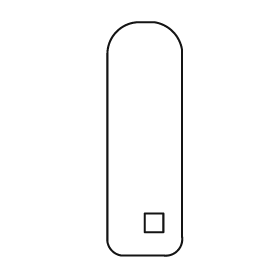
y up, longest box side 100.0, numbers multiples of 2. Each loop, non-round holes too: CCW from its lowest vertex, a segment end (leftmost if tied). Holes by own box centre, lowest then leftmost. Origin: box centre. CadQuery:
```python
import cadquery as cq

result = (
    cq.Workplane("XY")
    .moveTo(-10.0, -50.0)
    .lineTo(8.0, -50.0)
    .threePointArc((14.0, -48.0), (16.0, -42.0))
    .lineTo(16.0, 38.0)
    .threePointArc((12.0, 46.0), (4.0, 50.0))
    .lineTo(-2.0, 50.0)
    .threePointArc((-12.0, 46.0), (-16.0, 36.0))
    .lineTo(-16.0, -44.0)
    .threePointArc((-14.0, -48.0), (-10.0, -50.0))
    .close()
    .moveTo(0.0, -40.0)
    .lineTo(8.0, -40.0)
    .lineTo(8.0, -32.0)
    .lineTo(0.0, -32.0)
    .close()
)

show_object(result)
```